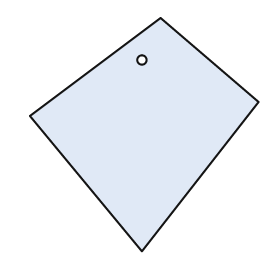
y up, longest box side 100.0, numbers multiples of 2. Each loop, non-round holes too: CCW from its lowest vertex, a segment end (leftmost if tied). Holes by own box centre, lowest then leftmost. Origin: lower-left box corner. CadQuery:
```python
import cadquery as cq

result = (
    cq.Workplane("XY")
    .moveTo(48.0, 0.0)
    .lineTo(98.0, 64.0)
    .lineTo(56.0, 100.0)
    .lineTo(0.0, 58.0)
    .close()
    .moveTo(48.0, 82.0)
    .circle(2.0)
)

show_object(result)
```